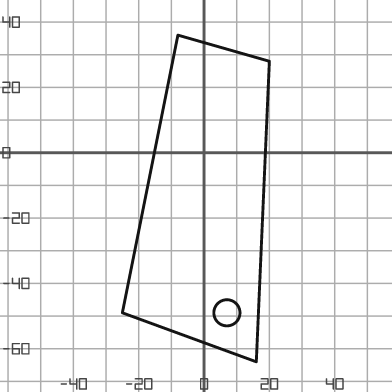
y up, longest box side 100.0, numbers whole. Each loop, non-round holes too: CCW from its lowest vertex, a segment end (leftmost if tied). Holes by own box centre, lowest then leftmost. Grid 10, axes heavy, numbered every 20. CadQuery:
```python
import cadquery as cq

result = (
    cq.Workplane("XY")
    .moveTo(16.0, -64.0)
    .lineTo(20.0, 28.0)
    .lineTo(-8.0, 36.0)
    .lineTo(-25.0, -49.0)
    .close()
    .moveTo(7.0, -49.0)
    .circle(4.0)
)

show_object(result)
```